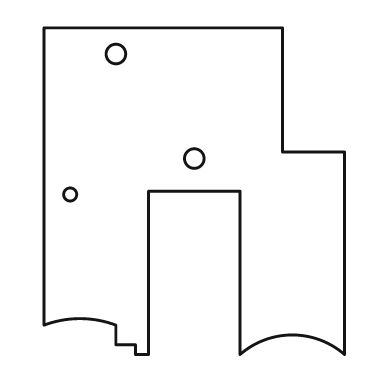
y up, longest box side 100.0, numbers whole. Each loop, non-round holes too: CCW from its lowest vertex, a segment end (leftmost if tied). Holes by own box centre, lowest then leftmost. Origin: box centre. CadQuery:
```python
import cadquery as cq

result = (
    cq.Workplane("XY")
    .moveTo(-18.0, -50.0)
    .lineTo(-14.0, -50.0)
    .lineTo(-14.0, 0.0)
    .lineTo(14.0, 0.0)
    .lineTo(14.0, -50.0)
    .threePointArc((30.0, -44.0), (46.0, -50.0))
    .lineTo(46.0, 12.0)
    .lineTo(27.0, 12.0)
    .lineTo(27.0, 50.0)
    .lineTo(-46.0, 50.0)
    .lineTo(-46.0, -41.0)
    .threePointArc((-35.0, -39.0), (-24.0, -41.0))
    .lineTo(-24.0, -47.0)
    .lineTo(-18.0, -47.0)
    .close()
    .moveTo(-38.0, -1.0)
    .circle(2.0)
    .moveTo(0.0, 10.0)
    .circle(3.0)
    .moveTo(-24.0, 42.0)
    .circle(3.0)
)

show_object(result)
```